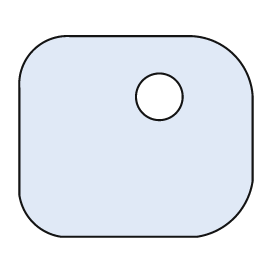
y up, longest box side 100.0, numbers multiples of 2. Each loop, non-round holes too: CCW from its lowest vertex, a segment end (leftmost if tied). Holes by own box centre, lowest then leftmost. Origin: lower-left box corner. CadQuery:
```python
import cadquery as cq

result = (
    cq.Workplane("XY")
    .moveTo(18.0, 0.0)
    .lineTo(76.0, 0.0)
    .threePointArc((92.0, 8.0), (100.0, 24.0))
    .lineTo(100.0, 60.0)
    .threePointArc((92.0, 78.0), (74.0, 86.0))
    .lineTo(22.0, 86.0)
    .threePointArc((6.0, 80.0), (0.0, 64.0))
    .lineTo(0.0, 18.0)
    .threePointArc((6.0, 6.0), (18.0, 0.0))
    .close()
    .moveTo(60.0, 60.0)
    .circle(10.0)
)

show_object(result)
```